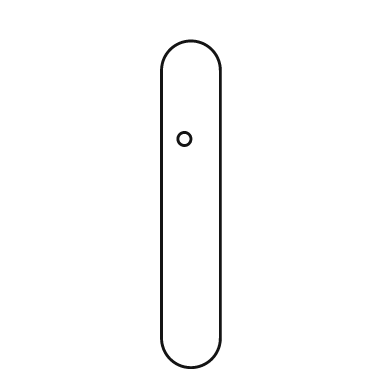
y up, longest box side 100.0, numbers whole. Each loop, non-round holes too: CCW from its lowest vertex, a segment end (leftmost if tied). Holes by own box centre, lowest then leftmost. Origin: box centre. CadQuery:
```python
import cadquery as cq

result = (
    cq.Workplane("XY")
    .moveTo(-9.0, -41.0)
    .threePointArc((0.0, -50.0), (9.0, -41.0))
    .lineTo(9.0, 41.0)
    .threePointArc((0.0, 50.0), (-9.0, 41.0))
    .close()
    .moveTo(-2.0, 20.0)
    .circle(2.0)
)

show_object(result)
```